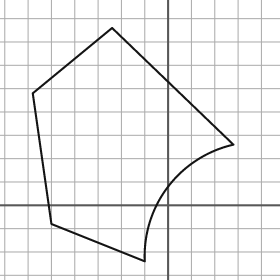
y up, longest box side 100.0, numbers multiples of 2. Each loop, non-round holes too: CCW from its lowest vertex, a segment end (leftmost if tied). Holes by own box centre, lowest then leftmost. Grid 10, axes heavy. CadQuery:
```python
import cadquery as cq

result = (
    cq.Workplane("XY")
    .moveTo(-10.0, -24.0)
    .threePointArc((0.0, 8.0), (28.0, 26.0))
    .lineTo(-24.0, 76.0)
    .lineTo(-58.0, 48.0)
    .lineTo(-50.0, -8.0)
    .close()
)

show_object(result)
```